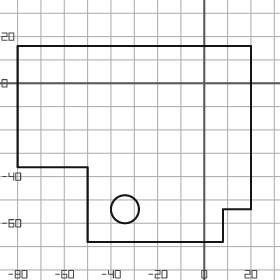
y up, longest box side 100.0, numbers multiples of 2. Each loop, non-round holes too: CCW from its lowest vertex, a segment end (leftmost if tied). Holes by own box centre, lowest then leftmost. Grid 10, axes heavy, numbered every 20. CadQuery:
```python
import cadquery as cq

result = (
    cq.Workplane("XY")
    .moveTo(-50.0, -68.0)
    .lineTo(8.0, -68.0)
    .lineTo(8.0, -54.0)
    .lineTo(20.0, -54.0)
    .lineTo(20.0, 16.0)
    .lineTo(-80.0, 16.0)
    .lineTo(-80.0, -36.0)
    .lineTo(-50.0, -36.0)
    .close()
    .moveTo(-34.0, -54.0)
    .circle(6.0)
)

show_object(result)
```